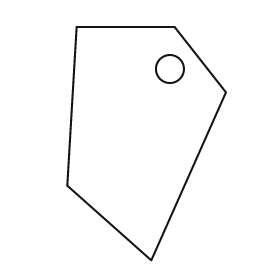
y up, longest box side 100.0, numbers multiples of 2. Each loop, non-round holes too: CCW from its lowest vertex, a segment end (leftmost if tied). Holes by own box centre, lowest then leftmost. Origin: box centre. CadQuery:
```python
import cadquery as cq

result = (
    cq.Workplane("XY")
    .moveTo(2.0, -50.0)
    .lineTo(34.0, 22.0)
    .lineTo(12.0, 50.0)
    .lineTo(-30.0, 50.0)
    .lineTo(-34.0, -18.0)
    .close()
    .moveTo(10.0, 32.0)
    .circle(6.0)
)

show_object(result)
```